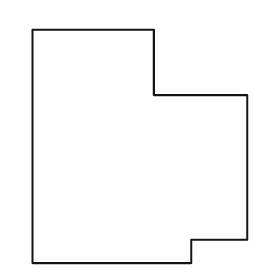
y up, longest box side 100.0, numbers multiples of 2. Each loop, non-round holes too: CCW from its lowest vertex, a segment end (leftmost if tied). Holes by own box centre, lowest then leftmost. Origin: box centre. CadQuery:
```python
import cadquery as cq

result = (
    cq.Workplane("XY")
    .moveTo(-46.0, -50.0)
    .lineTo(22.0, -50.0)
    .lineTo(22.0, -40.0)
    .lineTo(46.0, -40.0)
    .lineTo(46.0, 22.0)
    .lineTo(6.0, 22.0)
    .lineTo(6.0, 50.0)
    .lineTo(-46.0, 50.0)
    .close()
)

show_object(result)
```